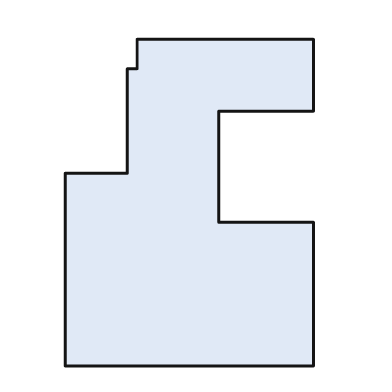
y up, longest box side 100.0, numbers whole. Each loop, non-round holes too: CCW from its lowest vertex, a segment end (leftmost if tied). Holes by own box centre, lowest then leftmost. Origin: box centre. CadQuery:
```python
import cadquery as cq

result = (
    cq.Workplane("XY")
    .moveTo(-38.0, -50.0)
    .lineTo(38.0, -50.0)
    .lineTo(38.0, -6.0)
    .lineTo(9.0, -6.0)
    .lineTo(9.0, 28.0)
    .lineTo(38.0, 28.0)
    .lineTo(38.0, 50.0)
    .lineTo(-16.0, 50.0)
    .lineTo(-16.0, 41.0)
    .lineTo(-19.0, 41.0)
    .lineTo(-19.0, 9.0)
    .lineTo(-38.0, 9.0)
    .close()
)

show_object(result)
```